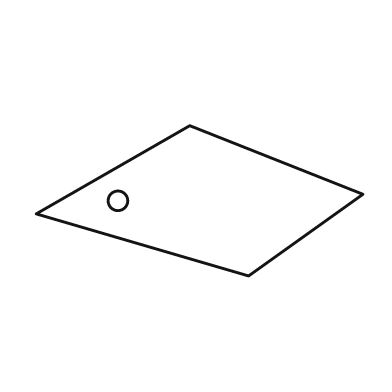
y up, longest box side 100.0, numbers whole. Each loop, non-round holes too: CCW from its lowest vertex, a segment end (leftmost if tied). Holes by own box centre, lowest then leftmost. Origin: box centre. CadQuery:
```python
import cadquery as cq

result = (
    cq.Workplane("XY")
    .moveTo(15.0, -23.0)
    .lineTo(50.0, 2.0)
    .lineTo(-3.0, 23.0)
    .lineTo(-50.0, -4.0)
    .close()
    .moveTo(-25.0, 0.0)
    .circle(3.0)
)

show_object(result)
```